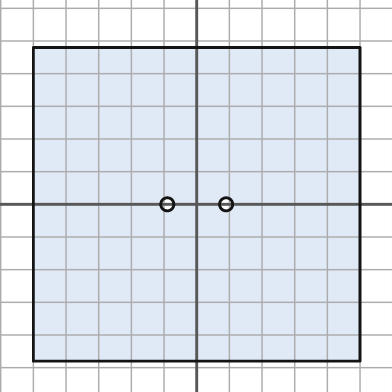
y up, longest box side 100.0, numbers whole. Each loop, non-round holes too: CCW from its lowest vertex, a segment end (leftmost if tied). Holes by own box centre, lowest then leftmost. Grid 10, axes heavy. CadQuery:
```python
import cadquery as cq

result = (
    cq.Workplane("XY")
    .moveTo(-50.0, -48.0)
    .lineTo(50.0, -48.0)
    .lineTo(50.0, 48.0)
    .lineTo(-50.0, 48.0)
    .close()
    .moveTo(-9.0, 0.0)
    .circle(2.0)
    .moveTo(9.0, 0.0)
    .circle(2.0)
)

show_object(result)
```